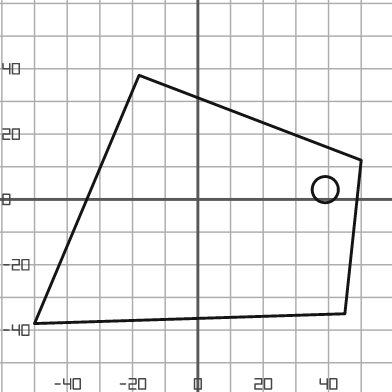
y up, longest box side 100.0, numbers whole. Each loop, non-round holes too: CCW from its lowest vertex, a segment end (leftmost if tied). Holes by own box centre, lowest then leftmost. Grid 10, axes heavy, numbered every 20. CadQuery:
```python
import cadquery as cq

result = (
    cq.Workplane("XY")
    .moveTo(-50.0, -38.0)
    .lineTo(45.0, -35.0)
    .lineTo(50.0, 12.0)
    .lineTo(-18.0, 38.0)
    .close()
    .moveTo(39.0, 3.0)
    .circle(4.0)
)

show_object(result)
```